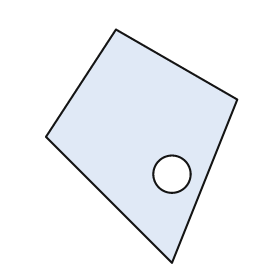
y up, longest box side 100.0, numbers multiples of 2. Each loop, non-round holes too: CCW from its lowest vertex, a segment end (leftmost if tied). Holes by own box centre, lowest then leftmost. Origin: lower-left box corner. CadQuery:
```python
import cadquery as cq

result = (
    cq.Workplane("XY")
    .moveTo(54.0, 0.0)
    .lineTo(82.0, 70.0)
    .lineTo(30.0, 100.0)
    .lineTo(0.0, 54.0)
    .close()
    .moveTo(54.0, 38.0)
    .circle(8.0)
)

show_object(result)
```